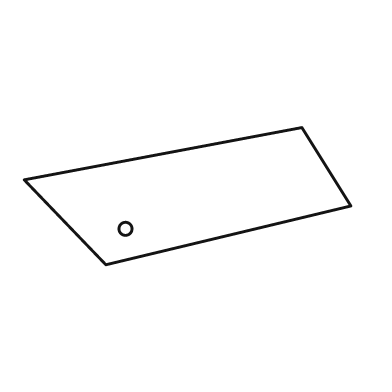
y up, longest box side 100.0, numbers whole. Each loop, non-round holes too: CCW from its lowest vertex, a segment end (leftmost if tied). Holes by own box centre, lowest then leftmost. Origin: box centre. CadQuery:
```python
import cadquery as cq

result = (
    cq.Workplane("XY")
    .moveTo(-25.0, -21.0)
    .lineTo(50.0, -3.0)
    .lineTo(35.0, 21.0)
    .lineTo(-50.0, 5.0)
    .close()
    .moveTo(-19.0, -10.0)
    .circle(2.0)
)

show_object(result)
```